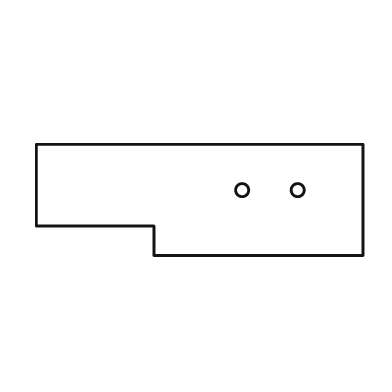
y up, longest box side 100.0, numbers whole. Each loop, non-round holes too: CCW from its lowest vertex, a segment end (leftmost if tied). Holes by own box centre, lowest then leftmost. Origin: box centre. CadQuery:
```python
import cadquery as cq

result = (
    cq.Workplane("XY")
    .moveTo(-14.0, -17.0)
    .lineTo(50.0, -17.0)
    .lineTo(50.0, 17.0)
    .lineTo(-50.0, 17.0)
    .lineTo(-50.0, -8.0)
    .lineTo(-14.0, -8.0)
    .close()
    .moveTo(13.0, 3.0)
    .circle(2.0)
    .moveTo(30.0, 3.0)
    .circle(2.0)
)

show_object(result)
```